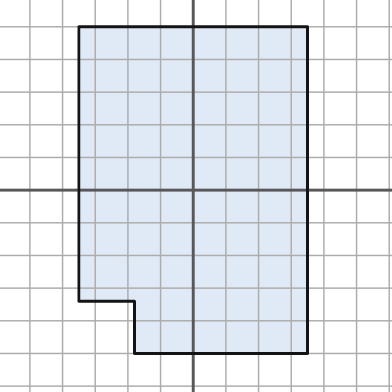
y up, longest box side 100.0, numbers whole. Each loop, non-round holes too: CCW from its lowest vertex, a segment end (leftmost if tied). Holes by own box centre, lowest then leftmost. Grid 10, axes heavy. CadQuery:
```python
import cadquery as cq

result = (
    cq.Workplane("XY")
    .moveTo(-18.0, -50.0)
    .lineTo(35.0, -50.0)
    .lineTo(35.0, 50.0)
    .lineTo(-35.0, 50.0)
    .lineTo(-35.0, -34.0)
    .lineTo(-18.0, -34.0)
    .close()
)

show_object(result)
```